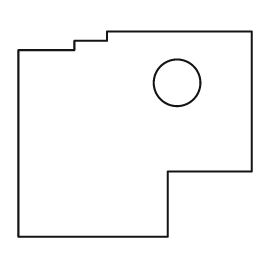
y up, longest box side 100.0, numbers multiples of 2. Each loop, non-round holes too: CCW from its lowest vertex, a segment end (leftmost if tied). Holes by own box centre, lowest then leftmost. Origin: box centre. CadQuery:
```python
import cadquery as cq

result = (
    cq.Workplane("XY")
    .moveTo(-50.0, -44.0)
    .lineTo(14.0, -44.0)
    .lineTo(14.0, -16.0)
    .lineTo(50.0, -16.0)
    .lineTo(50.0, 44.0)
    .lineTo(-12.0, 44.0)
    .lineTo(-12.0, 40.0)
    .lineTo(-26.0, 40.0)
    .lineTo(-26.0, 36.0)
    .lineTo(-50.0, 36.0)
    .close()
    .moveTo(18.0, 22.0)
    .circle(10.0)
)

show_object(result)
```